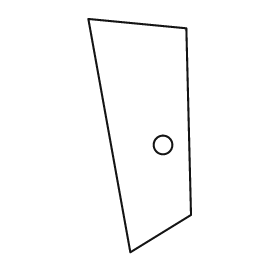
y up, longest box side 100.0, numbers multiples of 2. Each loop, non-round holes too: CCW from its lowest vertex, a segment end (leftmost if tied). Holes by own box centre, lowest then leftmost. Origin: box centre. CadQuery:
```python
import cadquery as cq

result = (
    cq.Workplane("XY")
    .moveTo(-4.0, -50.0)
    .lineTo(22.0, -34.0)
    .lineTo(20.0, 46.0)
    .lineTo(-22.0, 50.0)
    .close()
    .moveTo(10.0, -4.0)
    .circle(4.0)
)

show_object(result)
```